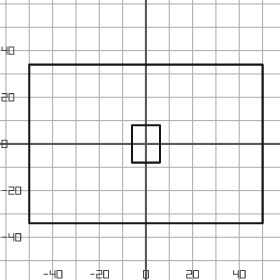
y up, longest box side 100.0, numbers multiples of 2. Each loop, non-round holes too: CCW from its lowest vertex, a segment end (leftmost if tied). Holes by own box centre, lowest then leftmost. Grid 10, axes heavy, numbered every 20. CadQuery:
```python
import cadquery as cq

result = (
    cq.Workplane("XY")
    .moveTo(-50.0, -34.0)
    .lineTo(50.0, -34.0)
    .lineTo(50.0, 34.0)
    .lineTo(-50.0, 34.0)
    .close()
    .moveTo(-6.0, -8.0)
    .lineTo(6.0, -8.0)
    .lineTo(6.0, 8.0)
    .lineTo(-6.0, 8.0)
    .close()
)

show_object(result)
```